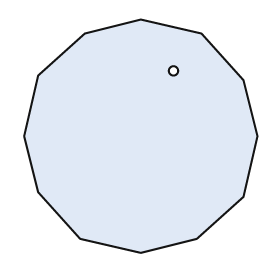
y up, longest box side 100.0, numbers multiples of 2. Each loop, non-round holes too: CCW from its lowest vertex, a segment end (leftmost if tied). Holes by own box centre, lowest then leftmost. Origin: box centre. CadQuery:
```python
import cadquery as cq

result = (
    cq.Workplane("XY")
    .moveTo(0.0, -50.0)
    .lineTo(24.0, -44.0)
    .lineTo(44.0, -26.0)
    .lineTo(50.0, 0.0)
    .lineTo(44.0, 24.0)
    .lineTo(26.0, 44.0)
    .lineTo(0.0, 50.0)
    .lineTo(-24.0, 44.0)
    .lineTo(-44.0, 26.0)
    .lineTo(-50.0, 0.0)
    .lineTo(-44.0, -24.0)
    .lineTo(-26.0, -44.0)
    .close()
    .moveTo(14.0, 28.0)
    .circle(2.0)
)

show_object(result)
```